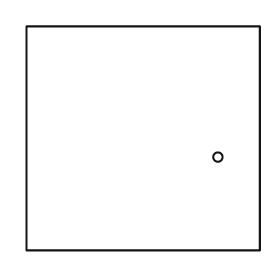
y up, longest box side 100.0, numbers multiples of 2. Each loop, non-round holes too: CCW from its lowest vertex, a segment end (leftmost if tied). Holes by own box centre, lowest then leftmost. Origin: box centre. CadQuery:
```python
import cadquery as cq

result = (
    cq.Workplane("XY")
    .moveTo(-50.0, -48.0)
    .lineTo(50.0, -48.0)
    .lineTo(50.0, 48.0)
    .lineTo(-50.0, 48.0)
    .close()
    .moveTo(32.0, -8.0)
    .circle(2.0)
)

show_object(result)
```